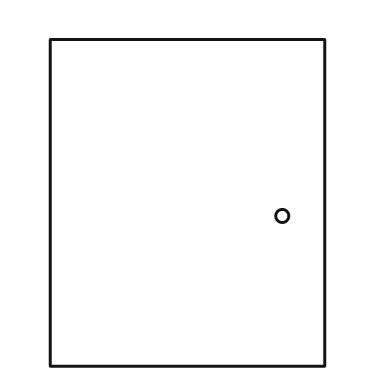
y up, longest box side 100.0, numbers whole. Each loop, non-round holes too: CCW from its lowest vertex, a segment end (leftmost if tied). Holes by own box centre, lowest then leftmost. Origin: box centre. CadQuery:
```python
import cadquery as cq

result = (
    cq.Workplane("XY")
    .moveTo(-42.0, -50.0)
    .lineTo(42.0, -50.0)
    .lineTo(42.0, 50.0)
    .lineTo(-42.0, 50.0)
    .close()
    .moveTo(29.0, -4.0)
    .circle(2.0)
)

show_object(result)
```